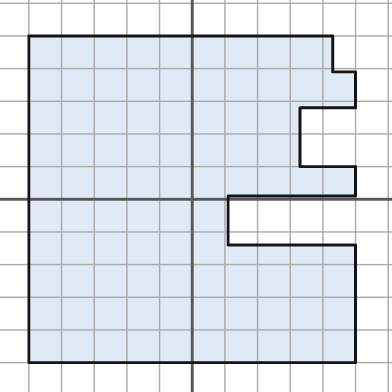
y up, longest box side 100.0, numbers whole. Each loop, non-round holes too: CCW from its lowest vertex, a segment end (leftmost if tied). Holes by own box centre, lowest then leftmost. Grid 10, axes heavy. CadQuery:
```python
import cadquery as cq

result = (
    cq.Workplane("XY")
    .moveTo(-50.0, -50.0)
    .lineTo(50.0, -50.0)
    .lineTo(50.0, -14.0)
    .lineTo(11.0, -14.0)
    .lineTo(11.0, 1.0)
    .lineTo(50.0, 1.0)
    .lineTo(50.0, 10.0)
    .lineTo(33.0, 10.0)
    .lineTo(33.0, 28.0)
    .lineTo(50.0, 28.0)
    .lineTo(50.0, 39.0)
    .lineTo(43.0, 39.0)
    .lineTo(43.0, 50.0)
    .lineTo(-50.0, 50.0)
    .close()
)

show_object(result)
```